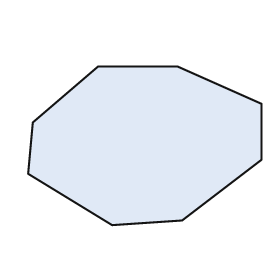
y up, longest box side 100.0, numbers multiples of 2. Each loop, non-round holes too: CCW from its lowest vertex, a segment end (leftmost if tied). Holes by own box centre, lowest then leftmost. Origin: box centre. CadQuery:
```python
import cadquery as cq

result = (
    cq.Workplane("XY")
    .moveTo(-14.0, -34.0)
    .lineTo(16.0, -32.0)
    .lineTo(50.0, -6.0)
    .lineTo(50.0, 18.0)
    .lineTo(14.0, 34.0)
    .lineTo(-20.0, 34.0)
    .lineTo(-48.0, 10.0)
    .lineTo(-50.0, -12.0)
    .close()
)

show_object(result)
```